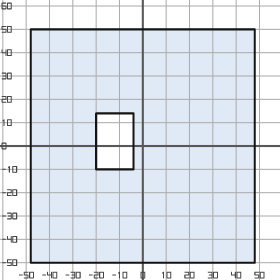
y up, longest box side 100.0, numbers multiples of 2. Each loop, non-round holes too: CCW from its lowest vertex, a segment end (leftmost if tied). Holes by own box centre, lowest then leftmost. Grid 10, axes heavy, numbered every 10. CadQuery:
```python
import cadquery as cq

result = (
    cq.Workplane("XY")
    .moveTo(-48.0, -50.0)
    .lineTo(48.0, -50.0)
    .lineTo(48.0, 50.0)
    .lineTo(-48.0, 50.0)
    .close()
    .moveTo(-20.0, -10.0)
    .lineTo(-4.0, -10.0)
    .lineTo(-4.0, 14.0)
    .lineTo(-20.0, 14.0)
    .close()
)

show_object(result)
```